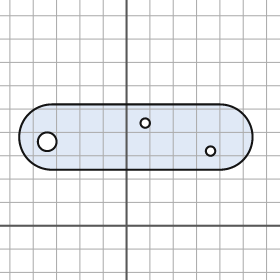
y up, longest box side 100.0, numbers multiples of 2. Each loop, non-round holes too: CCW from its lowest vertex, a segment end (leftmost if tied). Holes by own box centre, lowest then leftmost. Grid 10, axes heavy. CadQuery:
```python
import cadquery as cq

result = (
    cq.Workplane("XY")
    .moveTo(-32.0, 24.0)
    .lineTo(40.0, 24.0)
    .threePointArc((54.0, 38.0), (40.0, 52.0))
    .lineTo(-32.0, 52.0)
    .threePointArc((-46.0, 38.0), (-32.0, 24.0))
    .close()
    .moveTo(36.0, 32.0)
    .circle(2.0)
    .moveTo(-34.0, 36.0)
    .circle(4.0)
    .moveTo(8.0, 44.0)
    .circle(2.0)
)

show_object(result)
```